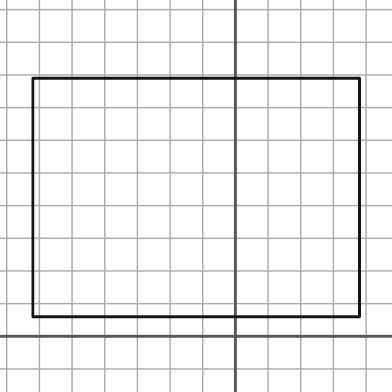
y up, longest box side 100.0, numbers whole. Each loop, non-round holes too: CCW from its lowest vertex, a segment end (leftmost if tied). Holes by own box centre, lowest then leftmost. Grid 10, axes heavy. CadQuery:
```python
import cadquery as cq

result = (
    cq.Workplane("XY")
    .moveTo(-62.0, 6.0)
    .lineTo(38.0, 6.0)
    .lineTo(38.0, 79.0)
    .lineTo(-62.0, 79.0)
    .close()
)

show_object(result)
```